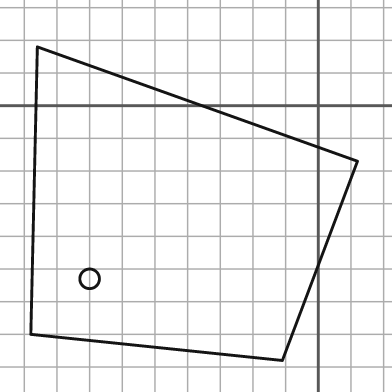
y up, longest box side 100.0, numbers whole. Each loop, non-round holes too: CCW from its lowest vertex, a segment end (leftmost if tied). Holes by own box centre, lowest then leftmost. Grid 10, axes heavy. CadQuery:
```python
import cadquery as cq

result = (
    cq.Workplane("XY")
    .moveTo(-11.0, -78.0)
    .lineTo(12.0, -17.0)
    .lineTo(-86.0, 18.0)
    .lineTo(-88.0, -70.0)
    .close()
    .moveTo(-70.0, -53.0)
    .circle(3.0)
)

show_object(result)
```